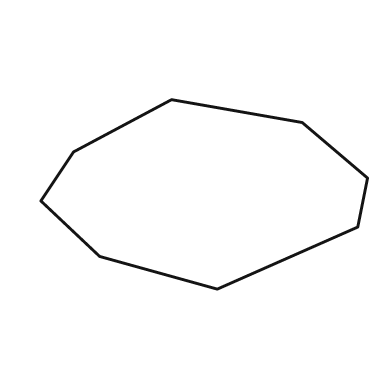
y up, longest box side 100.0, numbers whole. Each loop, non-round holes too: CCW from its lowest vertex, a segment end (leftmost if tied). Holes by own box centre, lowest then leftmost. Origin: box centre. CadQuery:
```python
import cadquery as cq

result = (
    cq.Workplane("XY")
    .moveTo(4.0, -29.0)
    .lineTo(47.0, -10.0)
    .lineTo(50.0, 5.0)
    .lineTo(30.0, 22.0)
    .lineTo(-10.0, 29.0)
    .lineTo(-40.0, 13.0)
    .lineTo(-50.0, -2.0)
    .lineTo(-32.0, -19.0)
    .close()
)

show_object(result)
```